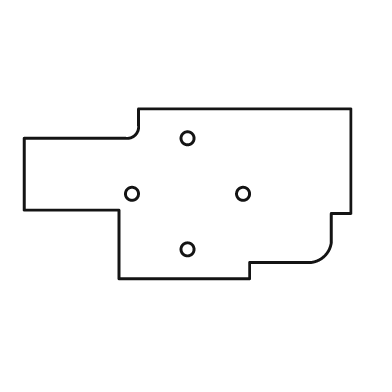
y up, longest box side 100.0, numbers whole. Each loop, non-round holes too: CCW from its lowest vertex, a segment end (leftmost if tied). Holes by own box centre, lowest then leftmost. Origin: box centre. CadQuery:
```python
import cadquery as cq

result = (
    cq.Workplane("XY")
    .moveTo(-21.0, -26.0)
    .lineTo(19.0, -26.0)
    .lineTo(19.0, -21.0)
    .lineTo(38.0, -21.0)
    .threePointArc((42.0, -19.0), (44.0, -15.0))
    .lineTo(44.0, -6.0)
    .lineTo(50.0, -6.0)
    .lineTo(50.0, 26.0)
    .lineTo(-15.0, 26.0)
    .lineTo(-15.0, 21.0)
    .threePointArc((-16.0, 18.0), (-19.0, 17.0))
    .lineTo(-50.0, 17.0)
    .lineTo(-50.0, -5.0)
    .lineTo(-21.0, -5.0)
    .close()
    .moveTo(0.0, -17.0)
    .circle(2.0)
    .moveTo(-17.0, 0.0)
    .circle(2.0)
    .moveTo(17.0, 0.0)
    .circle(2.0)
    .moveTo(0.0, 17.0)
    .circle(2.0)
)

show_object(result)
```